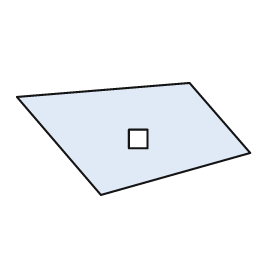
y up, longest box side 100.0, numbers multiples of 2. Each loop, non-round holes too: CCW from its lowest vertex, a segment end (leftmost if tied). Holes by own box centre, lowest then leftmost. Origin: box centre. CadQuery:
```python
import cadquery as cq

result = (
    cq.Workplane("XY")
    .moveTo(-14.0, -24.0)
    .lineTo(50.0, -6.0)
    .lineTo(24.0, 24.0)
    .lineTo(-50.0, 18.0)
    .close()
    .moveTo(-2.0, -4.0)
    .lineTo(6.0, -4.0)
    .lineTo(6.0, 4.0)
    .lineTo(-2.0, 4.0)
    .close()
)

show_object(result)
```